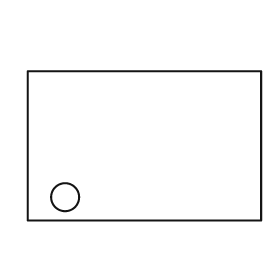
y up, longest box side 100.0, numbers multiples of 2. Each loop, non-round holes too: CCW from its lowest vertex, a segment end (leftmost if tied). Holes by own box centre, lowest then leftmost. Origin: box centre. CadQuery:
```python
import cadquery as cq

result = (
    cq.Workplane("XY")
    .moveTo(-50.0, -32.0)
    .lineTo(50.0, -32.0)
    .lineTo(50.0, 32.0)
    .lineTo(-50.0, 32.0)
    .close()
    .moveTo(-34.0, -22.0)
    .circle(6.0)
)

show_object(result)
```